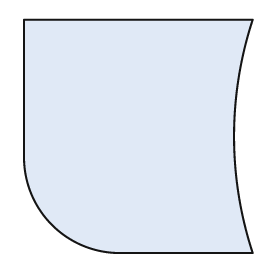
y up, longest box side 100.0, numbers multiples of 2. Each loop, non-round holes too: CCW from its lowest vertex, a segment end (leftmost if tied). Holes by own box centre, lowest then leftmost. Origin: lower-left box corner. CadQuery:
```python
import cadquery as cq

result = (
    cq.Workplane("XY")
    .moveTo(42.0, 0.0)
    .lineTo(98.0, 0.0)
    .threePointArc((90.0, 50.0), (98.0, 100.0))
    .lineTo(0.0, 100.0)
    .lineTo(0.0, 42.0)
    .threePointArc((12.0, 12.0), (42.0, 0.0))
    .close()
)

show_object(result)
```